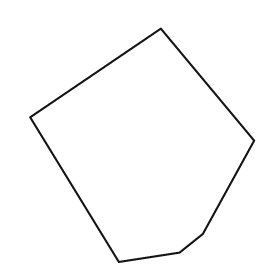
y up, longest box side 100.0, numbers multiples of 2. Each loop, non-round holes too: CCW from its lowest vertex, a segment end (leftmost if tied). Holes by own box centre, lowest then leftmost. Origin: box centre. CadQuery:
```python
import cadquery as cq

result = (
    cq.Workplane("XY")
    .moveTo(-10.0, -50.0)
    .lineTo(16.0, -46.0)
    .lineTo(26.0, -38.0)
    .lineTo(48.0, 2.0)
    .lineTo(8.0, 50.0)
    .lineTo(-48.0, 12.0)
    .close()
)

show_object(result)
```